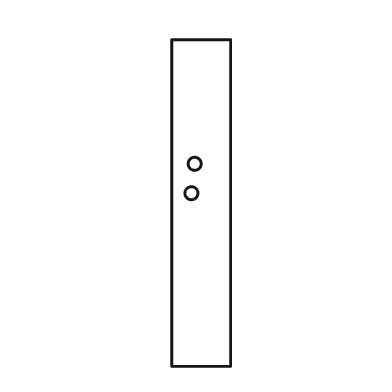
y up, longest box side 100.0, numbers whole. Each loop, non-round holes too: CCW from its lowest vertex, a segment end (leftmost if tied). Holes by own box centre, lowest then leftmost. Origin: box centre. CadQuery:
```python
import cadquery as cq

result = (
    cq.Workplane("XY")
    .moveTo(-9.0, -50.0)
    .lineTo(9.0, -50.0)
    .lineTo(9.0, 50.0)
    .lineTo(-9.0, 50.0)
    .close()
    .moveTo(-3.0, 3.0)
    .circle(2.0)
    .moveTo(-2.0, 12.0)
    .circle(2.0)
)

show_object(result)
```